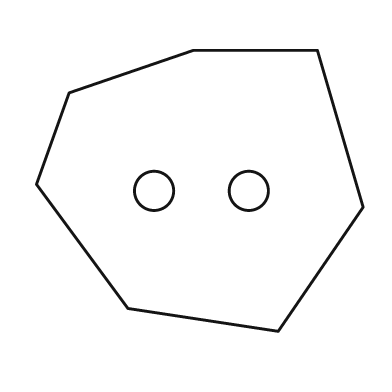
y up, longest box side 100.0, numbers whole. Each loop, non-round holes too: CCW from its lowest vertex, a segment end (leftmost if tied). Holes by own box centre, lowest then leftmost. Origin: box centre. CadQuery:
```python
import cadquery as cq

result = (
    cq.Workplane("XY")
    .moveTo(24.0, -43.0)
    .lineTo(50.0, -5.0)
    .lineTo(36.0, 43.0)
    .lineTo(-2.0, 43.0)
    .lineTo(-40.0, 30.0)
    .lineTo(-50.0, 2.0)
    .lineTo(-22.0, -36.0)
    .close()
    .moveTo(-14.0, 0.0)
    .circle(6.0)
    .moveTo(15.0, 0.0)
    .circle(6.0)
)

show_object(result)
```